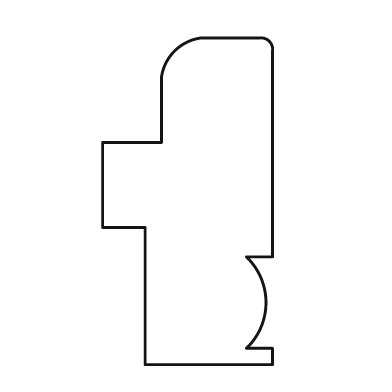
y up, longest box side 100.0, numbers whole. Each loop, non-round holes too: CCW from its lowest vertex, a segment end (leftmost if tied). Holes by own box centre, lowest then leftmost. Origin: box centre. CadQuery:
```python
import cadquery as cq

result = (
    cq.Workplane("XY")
    .moveTo(-13.0, -50.0)
    .lineTo(26.0, -50.0)
    .lineTo(26.0, -45.0)
    .lineTo(18.0, -45.0)
    .threePointArc((24.0, -31.0), (18.0, -17.0))
    .lineTo(26.0, -17.0)
    .lineTo(26.0, 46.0)
    .threePointArc((25.0, 49.0), (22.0, 50.0))
    .lineTo(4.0, 50.0)
    .threePointArc((-4.0, 46.0), (-8.0, 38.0))
    .lineTo(-8.0, 18.0)
    .lineTo(-26.0, 18.0)
    .lineTo(-26.0, -8.0)
    .lineTo(-13.0, -8.0)
    .close()
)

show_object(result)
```